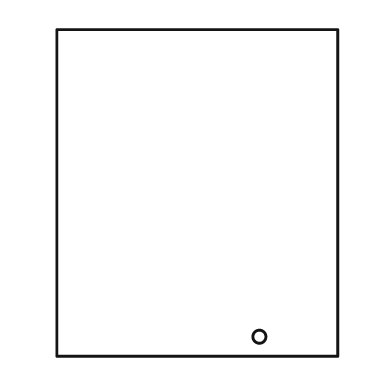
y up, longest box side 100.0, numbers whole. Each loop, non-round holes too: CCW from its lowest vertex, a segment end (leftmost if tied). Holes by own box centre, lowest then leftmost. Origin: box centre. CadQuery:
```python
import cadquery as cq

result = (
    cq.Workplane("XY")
    .moveTo(-43.0, -50.0)
    .lineTo(43.0, -50.0)
    .lineTo(43.0, 50.0)
    .lineTo(-43.0, 50.0)
    .close()
    .moveTo(19.0, -44.0)
    .circle(2.0)
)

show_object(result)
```